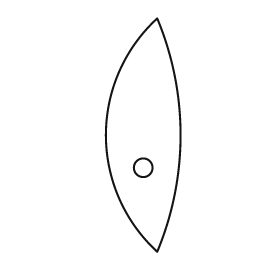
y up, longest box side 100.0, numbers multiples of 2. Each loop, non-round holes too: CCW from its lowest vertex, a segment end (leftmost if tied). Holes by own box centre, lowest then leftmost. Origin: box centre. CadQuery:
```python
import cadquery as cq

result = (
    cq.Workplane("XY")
    .moveTo(6.0, -50.0)
    .threePointArc((16.0, 0.0), (6.0, 50.0))
    .threePointArc((-16.0, 0.0), (6.0, -50.0))
    .close()
    .moveTo(0.0, -14.0)
    .circle(4.0)
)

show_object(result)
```